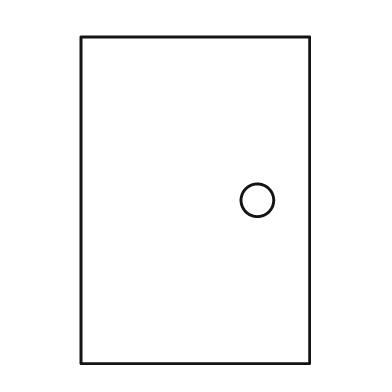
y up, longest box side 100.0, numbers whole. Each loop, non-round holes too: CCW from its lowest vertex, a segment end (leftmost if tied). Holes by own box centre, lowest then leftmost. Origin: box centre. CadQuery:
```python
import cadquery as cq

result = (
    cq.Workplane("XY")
    .moveTo(-35.0, -50.0)
    .lineTo(35.0, -50.0)
    .lineTo(35.0, 50.0)
    .lineTo(-35.0, 50.0)
    .close()
    .moveTo(19.0, 0.0)
    .circle(5.0)
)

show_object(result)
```